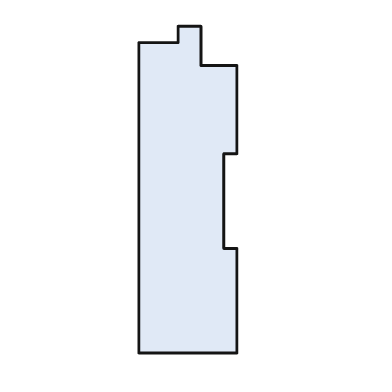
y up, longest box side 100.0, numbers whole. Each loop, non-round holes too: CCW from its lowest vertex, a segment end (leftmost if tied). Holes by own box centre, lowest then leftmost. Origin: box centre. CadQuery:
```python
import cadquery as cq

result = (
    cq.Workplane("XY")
    .moveTo(-15.0, -50.0)
    .lineTo(15.0, -50.0)
    .lineTo(15.0, -18.0)
    .lineTo(11.0, -18.0)
    .lineTo(11.0, 11.0)
    .lineTo(15.0, 11.0)
    .lineTo(15.0, 38.0)
    .lineTo(4.0, 38.0)
    .lineTo(4.0, 50.0)
    .lineTo(-3.0, 50.0)
    .lineTo(-3.0, 45.0)
    .lineTo(-15.0, 45.0)
    .close()
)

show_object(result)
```